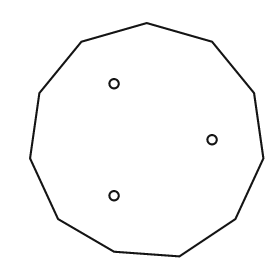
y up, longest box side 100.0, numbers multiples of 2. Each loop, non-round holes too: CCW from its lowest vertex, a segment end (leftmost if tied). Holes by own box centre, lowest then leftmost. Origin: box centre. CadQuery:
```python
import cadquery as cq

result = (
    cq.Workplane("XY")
    .moveTo(14.0, -50.0)
    .lineTo(38.0, -34.0)
    .lineTo(50.0, -8.0)
    .lineTo(46.0, 20.0)
    .lineTo(28.0, 42.0)
    .lineTo(0.0, 50.0)
    .lineTo(-28.0, 42.0)
    .lineTo(-46.0, 20.0)
    .lineTo(-50.0, -8.0)
    .lineTo(-38.0, -34.0)
    .lineTo(-14.0, -48.0)
    .close()
    .moveTo(-14.0, -24.0)
    .circle(2.0)
    .moveTo(28.0, 0.0)
    .circle(2.0)
    .moveTo(-14.0, 24.0)
    .circle(2.0)
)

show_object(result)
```